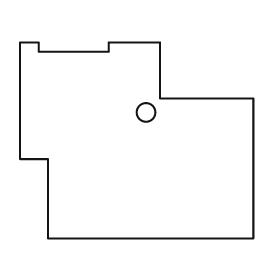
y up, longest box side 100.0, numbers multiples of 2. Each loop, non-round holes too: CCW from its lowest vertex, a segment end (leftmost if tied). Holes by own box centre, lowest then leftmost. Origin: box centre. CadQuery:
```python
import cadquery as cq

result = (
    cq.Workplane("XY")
    .moveTo(-38.0, -42.0)
    .lineTo(50.0, -42.0)
    .lineTo(50.0, 18.0)
    .lineTo(10.0, 18.0)
    .lineTo(10.0, 42.0)
    .lineTo(-12.0, 42.0)
    .lineTo(-12.0, 38.0)
    .lineTo(-42.0, 38.0)
    .lineTo(-42.0, 42.0)
    .lineTo(-50.0, 42.0)
    .lineTo(-50.0, -8.0)
    .lineTo(-38.0, -8.0)
    .close()
    .moveTo(4.0, 12.0)
    .circle(4.0)
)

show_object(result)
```